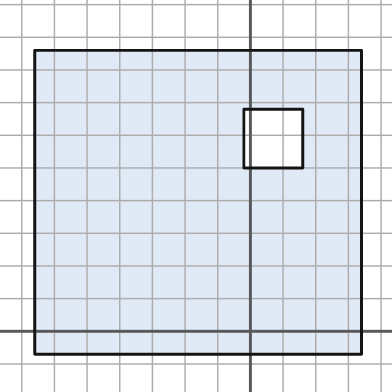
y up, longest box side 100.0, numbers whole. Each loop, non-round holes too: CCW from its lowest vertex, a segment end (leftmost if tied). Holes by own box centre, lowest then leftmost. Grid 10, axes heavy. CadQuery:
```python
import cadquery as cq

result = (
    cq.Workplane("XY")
    .moveTo(-66.0, -7.0)
    .lineTo(34.0, -7.0)
    .lineTo(34.0, 86.0)
    .lineTo(-66.0, 86.0)
    .close()
    .moveTo(-2.0, 50.0)
    .lineTo(16.0, 50.0)
    .lineTo(16.0, 68.0)
    .lineTo(-2.0, 68.0)
    .close()
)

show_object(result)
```